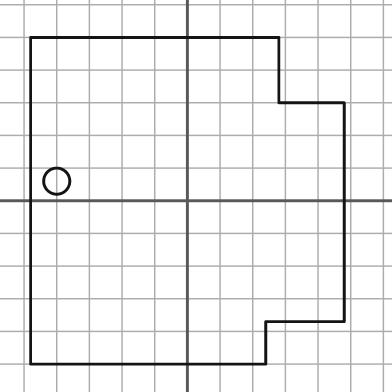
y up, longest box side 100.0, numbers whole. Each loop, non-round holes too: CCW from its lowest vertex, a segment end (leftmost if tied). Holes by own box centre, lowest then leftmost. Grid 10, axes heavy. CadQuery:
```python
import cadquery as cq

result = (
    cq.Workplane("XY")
    .moveTo(-48.0, -50.0)
    .lineTo(24.0, -50.0)
    .lineTo(24.0, -37.0)
    .lineTo(48.0, -37.0)
    .lineTo(48.0, 30.0)
    .lineTo(28.0, 30.0)
    .lineTo(28.0, 50.0)
    .lineTo(-48.0, 50.0)
    .close()
    .moveTo(-40.0, 6.0)
    .circle(4.0)
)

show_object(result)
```